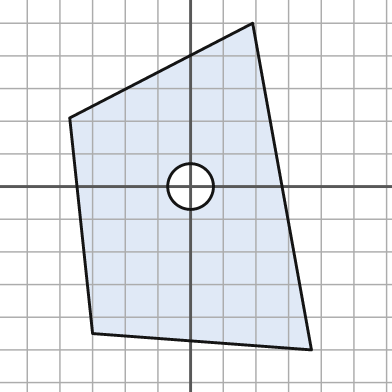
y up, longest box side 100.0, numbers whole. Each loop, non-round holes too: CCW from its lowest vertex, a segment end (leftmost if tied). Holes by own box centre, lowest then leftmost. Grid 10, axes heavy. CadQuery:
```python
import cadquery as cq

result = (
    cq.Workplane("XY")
    .moveTo(37.0, -50.0)
    .lineTo(19.0, 50.0)
    .lineTo(-37.0, 21.0)
    .lineTo(-30.0, -45.0)
    .close()
    .moveTo(0.0, 0.0)
    .circle(7.0)
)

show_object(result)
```